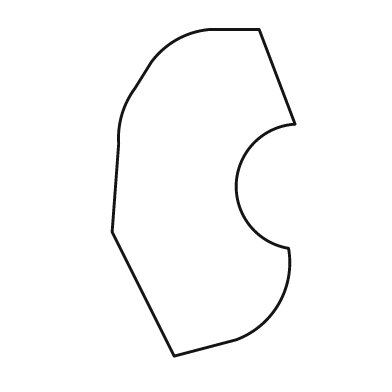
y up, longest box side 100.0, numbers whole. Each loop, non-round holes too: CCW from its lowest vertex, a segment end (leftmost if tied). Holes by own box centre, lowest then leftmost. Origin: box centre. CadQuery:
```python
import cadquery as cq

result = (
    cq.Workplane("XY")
    .moveTo(-9.0, -50.0)
    .lineTo(10.0, -45.0)
    .threePointArc((23.0, -34.0), (26.0, -17.0))
    .threePointArc((10.0, 3.0), (28.0, 21.0))
    .lineTo(17.0, 50.0)
    .lineTo(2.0, 50.0)
    .threePointArc((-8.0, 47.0), (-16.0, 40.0))
    .lineTo(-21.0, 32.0)
    .threePointArc((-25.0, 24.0), (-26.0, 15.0))
    .lineTo(-28.0, -12.0)
    .close()
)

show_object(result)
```